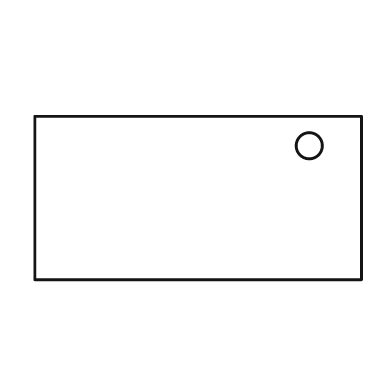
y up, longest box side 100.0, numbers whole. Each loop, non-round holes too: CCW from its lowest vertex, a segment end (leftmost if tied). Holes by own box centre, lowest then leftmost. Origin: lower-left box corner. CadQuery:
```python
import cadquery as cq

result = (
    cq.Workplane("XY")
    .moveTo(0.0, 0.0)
    .lineTo(100.0, 0.0)
    .lineTo(100.0, 50.0)
    .lineTo(0.0, 50.0)
    .close()
    .moveTo(84.0, 41.0)
    .circle(4.0)
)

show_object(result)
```